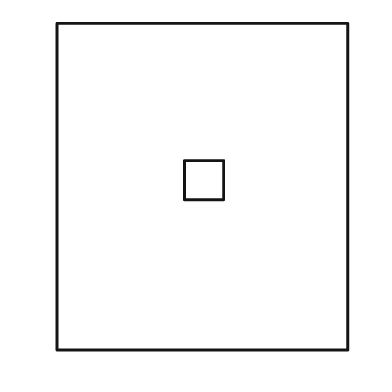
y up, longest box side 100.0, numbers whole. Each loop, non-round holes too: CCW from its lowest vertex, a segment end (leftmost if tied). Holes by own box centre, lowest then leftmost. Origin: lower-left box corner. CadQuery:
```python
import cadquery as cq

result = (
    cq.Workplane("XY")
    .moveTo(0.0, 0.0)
    .lineTo(89.0, 0.0)
    .lineTo(89.0, 100.0)
    .lineTo(0.0, 100.0)
    .close()
    .moveTo(39.0, 46.0)
    .lineTo(51.0, 46.0)
    .lineTo(51.0, 58.0)
    .lineTo(39.0, 58.0)
    .close()
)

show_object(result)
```